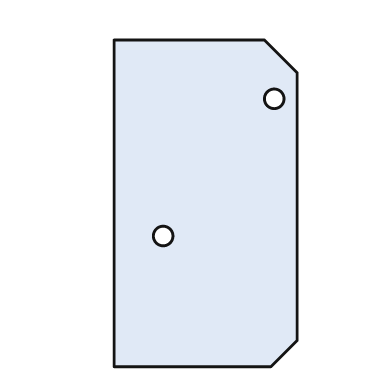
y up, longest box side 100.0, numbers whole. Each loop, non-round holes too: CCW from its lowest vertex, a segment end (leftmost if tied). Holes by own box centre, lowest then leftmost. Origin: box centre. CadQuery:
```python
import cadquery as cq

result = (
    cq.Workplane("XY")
    .moveTo(-28.0, -50.0)
    .lineTo(20.0, -50.0)
    .lineTo(28.0, -42.0)
    .lineTo(28.0, 40.0)
    .lineTo(18.0, 50.0)
    .lineTo(-28.0, 50.0)
    .close()
    .moveTo(-13.0, -10.0)
    .circle(3.0)
    .moveTo(21.0, 32.0)
    .circle(3.0)
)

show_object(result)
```